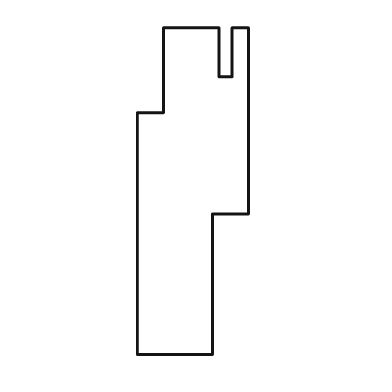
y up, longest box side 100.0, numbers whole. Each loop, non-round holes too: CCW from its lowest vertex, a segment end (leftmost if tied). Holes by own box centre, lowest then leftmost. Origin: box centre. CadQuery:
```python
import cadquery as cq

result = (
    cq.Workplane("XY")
    .moveTo(-17.0, -50.0)
    .lineTo(6.0, -50.0)
    .lineTo(6.0, -7.0)
    .lineTo(17.0, -7.0)
    .lineTo(17.0, 50.0)
    .lineTo(12.0, 50.0)
    .lineTo(12.0, 35.0)
    .lineTo(8.0, 35.0)
    .lineTo(8.0, 50.0)
    .lineTo(-9.0, 50.0)
    .lineTo(-9.0, 24.0)
    .lineTo(-17.0, 24.0)
    .close()
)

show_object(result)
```